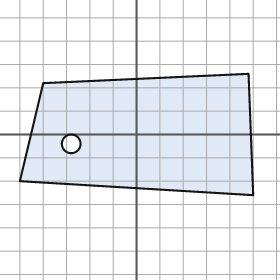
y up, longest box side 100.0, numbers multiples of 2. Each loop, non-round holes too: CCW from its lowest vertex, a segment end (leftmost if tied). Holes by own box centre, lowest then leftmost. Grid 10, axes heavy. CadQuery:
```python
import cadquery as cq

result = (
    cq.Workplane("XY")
    .moveTo(50.0, -26.0)
    .lineTo(48.0, 26.0)
    .lineTo(-40.0, 22.0)
    .lineTo(-50.0, -20.0)
    .close()
    .moveTo(-28.0, -4.0)
    .circle(4.0)
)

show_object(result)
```